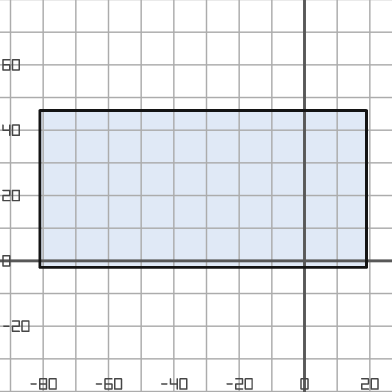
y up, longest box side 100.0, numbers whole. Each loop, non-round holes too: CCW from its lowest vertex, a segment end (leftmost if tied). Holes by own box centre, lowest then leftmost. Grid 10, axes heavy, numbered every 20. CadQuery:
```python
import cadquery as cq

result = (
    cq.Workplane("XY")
    .moveTo(-81.0, -2.0)
    .lineTo(19.0, -2.0)
    .lineTo(19.0, 46.0)
    .lineTo(-81.0, 46.0)
    .close()
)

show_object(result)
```